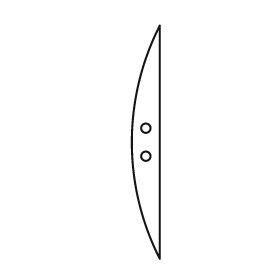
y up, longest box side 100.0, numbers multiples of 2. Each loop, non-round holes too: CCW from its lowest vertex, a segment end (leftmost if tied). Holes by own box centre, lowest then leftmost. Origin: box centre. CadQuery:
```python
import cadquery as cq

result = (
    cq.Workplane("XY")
    .moveTo(6.0, -50.0)
    .lineTo(6.0, 50.0)
    .threePointArc((-6.0, 0.0), (6.0, -50.0))
    .close()
    .moveTo(0.0, -6.0)
    .circle(2.0)
    .moveTo(0.0, 6.0)
    .circle(2.0)
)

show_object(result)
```